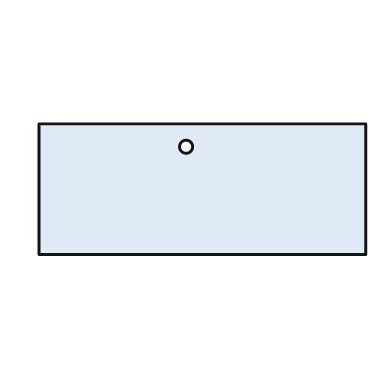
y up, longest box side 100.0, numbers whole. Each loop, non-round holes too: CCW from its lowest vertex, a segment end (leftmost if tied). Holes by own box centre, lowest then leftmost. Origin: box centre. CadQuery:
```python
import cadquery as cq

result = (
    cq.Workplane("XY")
    .moveTo(-50.0, -20.0)
    .lineTo(50.0, -20.0)
    .lineTo(50.0, 20.0)
    .lineTo(-50.0, 20.0)
    .close()
    .moveTo(-5.0, 13.0)
    .circle(2.0)
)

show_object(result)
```